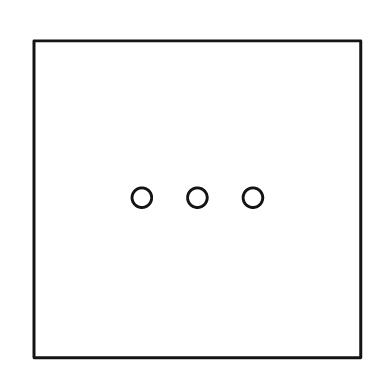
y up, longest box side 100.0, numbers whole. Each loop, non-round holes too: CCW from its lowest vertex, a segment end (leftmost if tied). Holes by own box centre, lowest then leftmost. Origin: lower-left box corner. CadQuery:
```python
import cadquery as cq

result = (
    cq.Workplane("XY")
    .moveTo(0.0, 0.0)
    .lineTo(100.0, 0.0)
    .lineTo(100.0, 97.0)
    .lineTo(0.0, 97.0)
    .close()
    .moveTo(33.0, 49.0)
    .circle(3.0)
    .moveTo(50.0, 49.0)
    .circle(3.0)
    .moveTo(67.0, 49.0)
    .circle(3.0)
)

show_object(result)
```